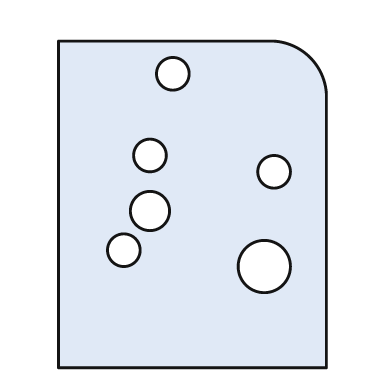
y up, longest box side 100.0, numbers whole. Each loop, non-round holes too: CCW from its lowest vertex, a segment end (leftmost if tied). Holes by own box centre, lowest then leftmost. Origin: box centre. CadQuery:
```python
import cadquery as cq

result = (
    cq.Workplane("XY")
    .moveTo(-41.0, -50.0)
    .lineTo(41.0, -50.0)
    .lineTo(41.0, 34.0)
    .threePointArc((36.0, 45.0), (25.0, 50.0))
    .lineTo(-41.0, 50.0)
    .close()
    .moveTo(22.0, -19.0)
    .circle(8.0)
    .moveTo(-21.0, -14.0)
    .circle(5.0)
    .moveTo(-13.0, -2.0)
    .circle(6.0)
    .moveTo(25.0, 10.0)
    .circle(5.0)
    .moveTo(-13.0, 15.0)
    .circle(5.0)
    .moveTo(-6.0, 40.0)
    .circle(5.0)
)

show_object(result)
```